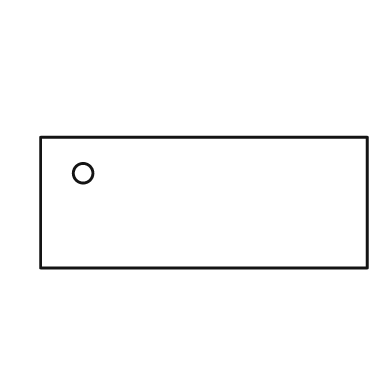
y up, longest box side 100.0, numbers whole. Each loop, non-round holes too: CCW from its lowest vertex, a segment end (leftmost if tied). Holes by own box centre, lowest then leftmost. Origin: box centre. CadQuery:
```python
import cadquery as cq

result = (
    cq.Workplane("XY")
    .moveTo(-50.0, -20.0)
    .lineTo(50.0, -20.0)
    .lineTo(50.0, 20.0)
    .lineTo(-50.0, 20.0)
    .close()
    .moveTo(-37.0, 9.0)
    .circle(3.0)
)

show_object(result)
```